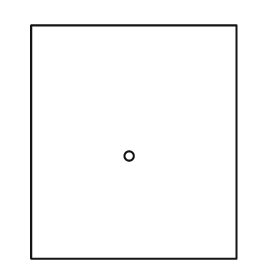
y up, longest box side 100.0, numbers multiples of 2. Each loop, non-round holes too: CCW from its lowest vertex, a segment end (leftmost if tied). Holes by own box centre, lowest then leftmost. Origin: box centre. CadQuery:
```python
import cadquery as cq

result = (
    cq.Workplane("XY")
    .moveTo(-44.0, -50.0)
    .lineTo(44.0, -50.0)
    .lineTo(44.0, 50.0)
    .lineTo(-44.0, 50.0)
    .close()
    .moveTo(-2.0, -6.0)
    .circle(2.0)
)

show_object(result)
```